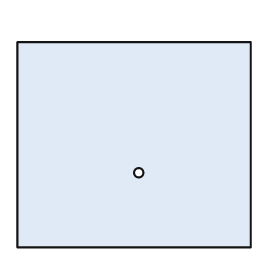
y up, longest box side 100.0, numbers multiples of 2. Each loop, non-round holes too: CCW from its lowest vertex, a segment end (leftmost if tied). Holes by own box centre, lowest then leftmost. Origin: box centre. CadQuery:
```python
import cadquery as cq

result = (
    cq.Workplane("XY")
    .moveTo(-50.0, -44.0)
    .lineTo(50.0, -44.0)
    .lineTo(50.0, 44.0)
    .lineTo(-50.0, 44.0)
    .close()
    .moveTo(2.0, -12.0)
    .circle(2.0)
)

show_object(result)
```